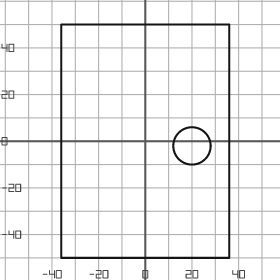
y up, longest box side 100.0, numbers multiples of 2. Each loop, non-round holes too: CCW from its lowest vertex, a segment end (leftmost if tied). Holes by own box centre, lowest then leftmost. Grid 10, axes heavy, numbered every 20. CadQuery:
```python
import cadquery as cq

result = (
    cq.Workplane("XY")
    .moveTo(-36.0, -50.0)
    .lineTo(36.0, -50.0)
    .lineTo(36.0, 50.0)
    .lineTo(-36.0, 50.0)
    .close()
    .moveTo(20.0, -2.0)
    .circle(8.0)
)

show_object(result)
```